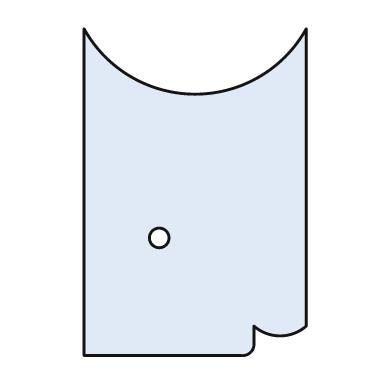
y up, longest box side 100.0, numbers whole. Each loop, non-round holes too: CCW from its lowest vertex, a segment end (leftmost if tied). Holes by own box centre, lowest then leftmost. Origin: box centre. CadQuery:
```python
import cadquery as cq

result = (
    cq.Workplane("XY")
    .moveTo(-34.0, -50.0)
    .lineTo(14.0, -50.0)
    .threePointArc((17.0, -49.0), (18.0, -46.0))
    .lineTo(18.0, -41.0)
    .threePointArc((26.0, -44.0), (34.0, -41.0))
    .lineTo(34.0, 50.0)
    .threePointArc((0.0, 30.0), (-34.0, 50.0))
    .close()
    .moveTo(-11.0, -14.0)
    .circle(3.0)
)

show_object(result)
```